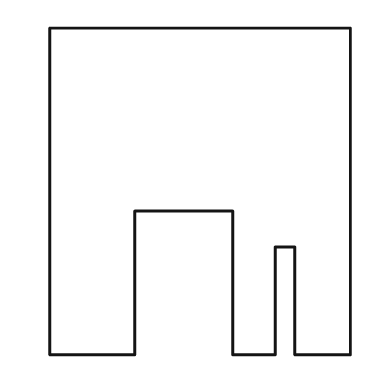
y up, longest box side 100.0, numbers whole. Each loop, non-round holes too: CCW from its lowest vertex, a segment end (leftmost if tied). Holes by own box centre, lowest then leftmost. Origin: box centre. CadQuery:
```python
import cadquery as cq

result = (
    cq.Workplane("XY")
    .moveTo(-46.0, -50.0)
    .lineTo(-20.0, -50.0)
    .lineTo(-20.0, -6.0)
    .lineTo(10.0, -6.0)
    .lineTo(10.0, -50.0)
    .lineTo(23.0, -50.0)
    .lineTo(23.0, -17.0)
    .lineTo(29.0, -17.0)
    .lineTo(29.0, -50.0)
    .lineTo(46.0, -50.0)
    .lineTo(46.0, 50.0)
    .lineTo(-46.0, 50.0)
    .close()
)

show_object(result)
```